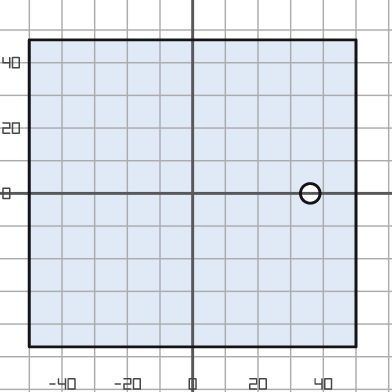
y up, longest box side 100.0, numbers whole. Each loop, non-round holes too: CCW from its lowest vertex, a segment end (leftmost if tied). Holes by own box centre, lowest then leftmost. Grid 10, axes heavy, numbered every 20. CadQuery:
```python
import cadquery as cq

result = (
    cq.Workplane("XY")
    .moveTo(-50.0, -47.0)
    .lineTo(50.0, -47.0)
    .lineTo(50.0, 47.0)
    .lineTo(-50.0, 47.0)
    .close()
    .moveTo(36.0, 0.0)
    .circle(3.0)
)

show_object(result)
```